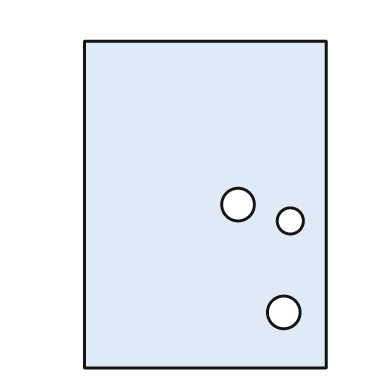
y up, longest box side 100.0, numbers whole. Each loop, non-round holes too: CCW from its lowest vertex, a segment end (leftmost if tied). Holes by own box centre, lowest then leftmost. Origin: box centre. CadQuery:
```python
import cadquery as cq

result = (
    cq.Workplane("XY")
    .moveTo(-37.0, -50.0)
    .lineTo(37.0, -50.0)
    .lineTo(37.0, 50.0)
    .lineTo(-37.0, 50.0)
    .close()
    .moveTo(24.0, -33.0)
    .circle(5.0)
    .moveTo(26.0, -5.0)
    .circle(4.0)
    .moveTo(10.0, 0.0)
    .circle(5.0)
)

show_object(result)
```